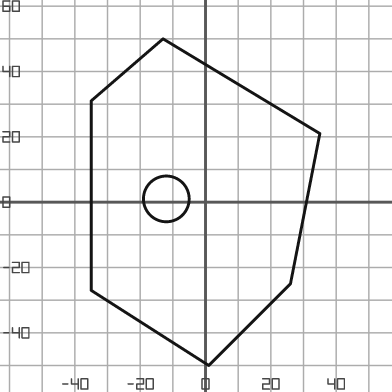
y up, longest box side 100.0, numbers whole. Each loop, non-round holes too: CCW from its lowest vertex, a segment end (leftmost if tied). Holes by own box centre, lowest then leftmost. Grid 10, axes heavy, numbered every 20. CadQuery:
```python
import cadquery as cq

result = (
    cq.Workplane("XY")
    .moveTo(1.0, -50.0)
    .lineTo(26.0, -25.0)
    .lineTo(35.0, 21.0)
    .lineTo(-13.0, 50.0)
    .lineTo(-35.0, 31.0)
    .lineTo(-35.0, -27.0)
    .close()
    .moveTo(-12.0, 1.0)
    .circle(7.0)
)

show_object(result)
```